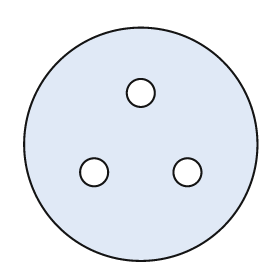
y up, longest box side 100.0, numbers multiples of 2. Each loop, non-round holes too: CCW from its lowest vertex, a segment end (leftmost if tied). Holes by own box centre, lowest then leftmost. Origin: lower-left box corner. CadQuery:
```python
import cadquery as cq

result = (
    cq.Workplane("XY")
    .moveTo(50.0, 50.0)
    .circle(50.0)
    .moveTo(30.0, 38.0)
    .circle(6.0)
    .moveTo(70.0, 38.0)
    .circle(6.0)
    .moveTo(50.0, 72.0)
    .circle(6.0)
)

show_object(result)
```